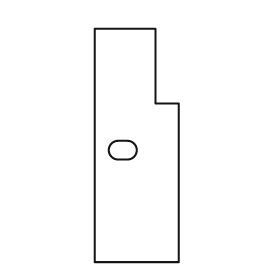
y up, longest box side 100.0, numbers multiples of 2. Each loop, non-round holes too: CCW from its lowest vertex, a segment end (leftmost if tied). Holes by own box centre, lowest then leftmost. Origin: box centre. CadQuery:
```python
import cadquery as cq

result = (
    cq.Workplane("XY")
    .moveTo(-18.0, -50.0)
    .lineTo(18.0, -50.0)
    .lineTo(18.0, 18.0)
    .lineTo(8.0, 18.0)
    .lineTo(8.0, 50.0)
    .lineTo(-18.0, 50.0)
    .close()
    .moveTo(-8.0, -6.0)
    .lineTo(-4.0, -6.0)
    .threePointArc((0.0, -2.0), (-4.0, 2.0))
    .lineTo(-8.0, 2.0)
    .threePointArc((-12.0, -2.0), (-8.0, -6.0))
    .close()
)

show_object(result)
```